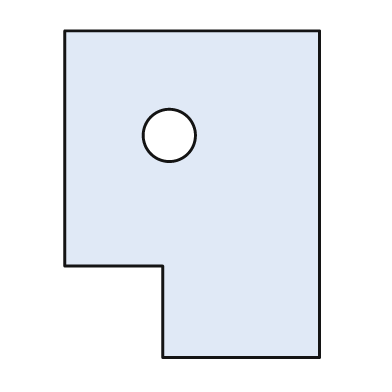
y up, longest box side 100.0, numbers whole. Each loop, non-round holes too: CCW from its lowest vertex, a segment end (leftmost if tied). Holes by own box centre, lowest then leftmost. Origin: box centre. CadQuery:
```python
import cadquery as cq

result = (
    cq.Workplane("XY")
    .moveTo(-9.0, -50.0)
    .lineTo(39.0, -50.0)
    .lineTo(39.0, 50.0)
    .lineTo(-39.0, 50.0)
    .lineTo(-39.0, -22.0)
    .lineTo(-9.0, -22.0)
    .close()
    .moveTo(-7.0, 18.0)
    .circle(8.0)
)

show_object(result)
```